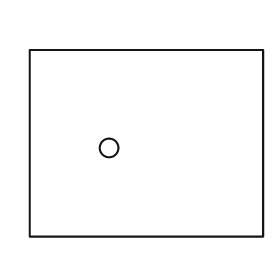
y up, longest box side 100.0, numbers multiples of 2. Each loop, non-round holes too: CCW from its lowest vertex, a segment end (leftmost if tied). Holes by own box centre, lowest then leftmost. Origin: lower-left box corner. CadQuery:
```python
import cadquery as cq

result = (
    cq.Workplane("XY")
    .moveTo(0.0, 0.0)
    .lineTo(100.0, 0.0)
    .lineTo(100.0, 80.0)
    .lineTo(0.0, 80.0)
    .close()
    .moveTo(34.0, 38.0)
    .circle(4.0)
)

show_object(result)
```